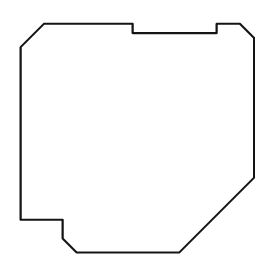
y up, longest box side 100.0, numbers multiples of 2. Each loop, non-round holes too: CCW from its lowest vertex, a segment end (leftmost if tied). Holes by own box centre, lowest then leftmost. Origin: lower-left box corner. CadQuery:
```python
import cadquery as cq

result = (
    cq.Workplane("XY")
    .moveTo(24.0, 0.0)
    .lineTo(68.0, 0.0)
    .lineTo(100.0, 32.0)
    .lineTo(100.0, 92.0)
    .lineTo(94.0, 98.0)
    .lineTo(84.0, 98.0)
    .lineTo(84.0, 94.0)
    .lineTo(48.0, 94.0)
    .lineTo(48.0, 98.0)
    .lineTo(10.0, 98.0)
    .lineTo(0.0, 88.0)
    .lineTo(0.0, 14.0)
    .lineTo(18.0, 14.0)
    .lineTo(18.0, 6.0)
    .close()
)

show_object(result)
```